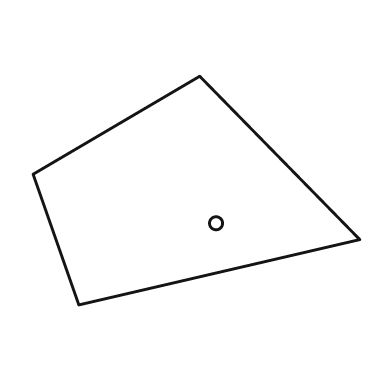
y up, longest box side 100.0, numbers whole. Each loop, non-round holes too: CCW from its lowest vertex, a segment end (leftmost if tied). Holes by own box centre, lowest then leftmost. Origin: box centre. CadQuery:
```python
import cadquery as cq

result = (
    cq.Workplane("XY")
    .moveTo(-36.0, -35.0)
    .lineTo(50.0, -15.0)
    .lineTo(1.0, 35.0)
    .lineTo(-50.0, 5.0)
    .close()
    .moveTo(6.0, -10.0)
    .circle(2.0)
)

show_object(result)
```